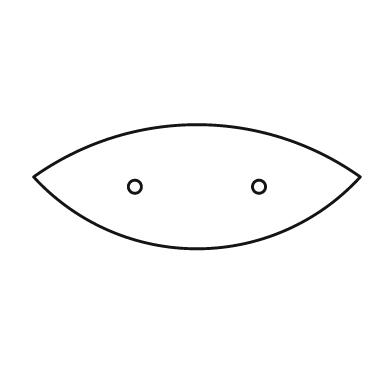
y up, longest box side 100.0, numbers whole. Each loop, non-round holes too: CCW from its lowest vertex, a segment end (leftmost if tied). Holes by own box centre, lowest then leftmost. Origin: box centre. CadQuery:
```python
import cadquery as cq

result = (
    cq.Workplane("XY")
    .moveTo(-50.0, 3.0)
    .threePointArc((0.0, -19.0), (50.0, 3.0))
    .threePointArc((0.0, 19.0), (-50.0, 3.0))
    .close()
    .moveTo(-19.0, 0.0)
    .circle(2.0)
    .moveTo(19.0, 0.0)
    .circle(2.0)
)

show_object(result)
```